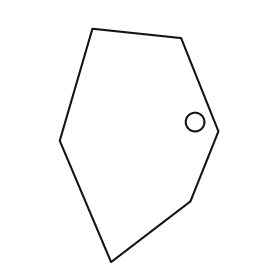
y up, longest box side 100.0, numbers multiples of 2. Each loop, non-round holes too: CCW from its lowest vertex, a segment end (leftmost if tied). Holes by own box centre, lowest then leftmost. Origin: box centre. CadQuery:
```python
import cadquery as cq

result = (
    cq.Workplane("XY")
    .moveTo(-12.0, -50.0)
    .lineTo(22.0, -24.0)
    .lineTo(34.0, 6.0)
    .lineTo(18.0, 46.0)
    .lineTo(-20.0, 50.0)
    .lineTo(-34.0, 2.0)
    .close()
    .moveTo(24.0, 10.0)
    .circle(4.0)
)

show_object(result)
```